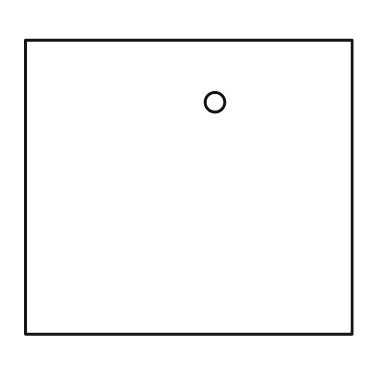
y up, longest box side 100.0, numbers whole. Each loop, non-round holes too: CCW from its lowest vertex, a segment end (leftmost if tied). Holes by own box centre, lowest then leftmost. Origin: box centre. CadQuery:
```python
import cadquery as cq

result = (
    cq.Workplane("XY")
    .moveTo(-50.0, -45.0)
    .lineTo(50.0, -45.0)
    .lineTo(50.0, 45.0)
    .lineTo(-50.0, 45.0)
    .close()
    .moveTo(8.0, 26.0)
    .circle(3.0)
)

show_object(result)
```